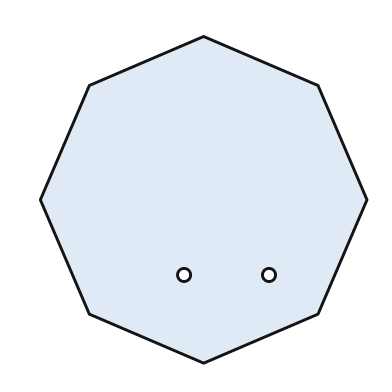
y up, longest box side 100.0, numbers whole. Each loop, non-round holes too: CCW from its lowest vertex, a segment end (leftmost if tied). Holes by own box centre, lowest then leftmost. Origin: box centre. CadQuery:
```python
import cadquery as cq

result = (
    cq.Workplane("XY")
    .moveTo(0.0, -50.0)
    .lineTo(35.0, -35.0)
    .lineTo(50.0, 0.0)
    .lineTo(35.0, 35.0)
    .lineTo(0.0, 50.0)
    .lineTo(-35.0, 35.0)
    .lineTo(-50.0, 0.0)
    .lineTo(-35.0, -35.0)
    .close()
    .moveTo(-6.0, -23.0)
    .circle(2.0)
    .moveTo(20.0, -23.0)
    .circle(2.0)
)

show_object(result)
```